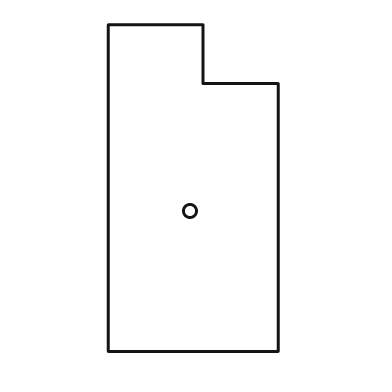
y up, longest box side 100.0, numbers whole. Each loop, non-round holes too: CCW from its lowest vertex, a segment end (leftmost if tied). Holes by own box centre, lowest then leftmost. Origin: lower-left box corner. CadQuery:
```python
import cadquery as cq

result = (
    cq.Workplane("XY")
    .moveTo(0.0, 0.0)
    .lineTo(52.0, 0.0)
    .lineTo(52.0, 82.0)
    .lineTo(29.0, 82.0)
    .lineTo(29.0, 100.0)
    .lineTo(0.0, 100.0)
    .close()
    .moveTo(25.0, 43.0)
    .circle(2.0)
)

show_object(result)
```